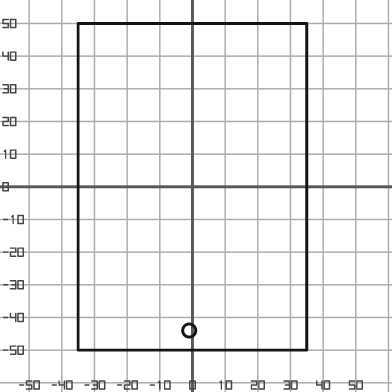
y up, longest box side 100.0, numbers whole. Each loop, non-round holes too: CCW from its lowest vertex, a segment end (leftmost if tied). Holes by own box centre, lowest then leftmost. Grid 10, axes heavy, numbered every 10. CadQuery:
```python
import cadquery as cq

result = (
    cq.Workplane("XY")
    .moveTo(-35.0, -50.0)
    .lineTo(35.0, -50.0)
    .lineTo(35.0, 50.0)
    .lineTo(-35.0, 50.0)
    .close()
    .moveTo(-1.0, -44.0)
    .circle(2.0)
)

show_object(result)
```